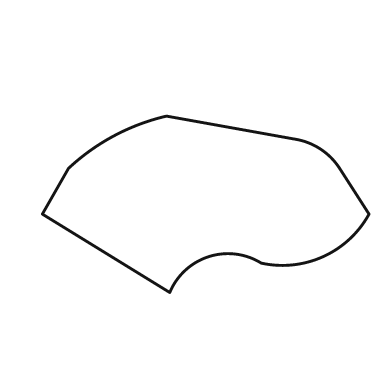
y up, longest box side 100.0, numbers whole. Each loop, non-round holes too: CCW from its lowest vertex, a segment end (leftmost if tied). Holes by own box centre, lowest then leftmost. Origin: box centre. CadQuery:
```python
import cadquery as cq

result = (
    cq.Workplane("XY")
    .moveTo(-11.0, -27.0)
    .threePointArc((1.0, -16.0), (17.0, -18.0))
    .threePointArc((36.0, -16.0), (50.0, -3.0))
    .lineTo(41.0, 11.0)
    .threePointArc((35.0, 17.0), (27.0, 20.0))
    .lineTo(-12.0, 27.0)
    .threePointArc((-28.0, 21.0), (-42.0, 11.0))
    .lineTo(-50.0, -3.0)
    .close()
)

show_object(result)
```